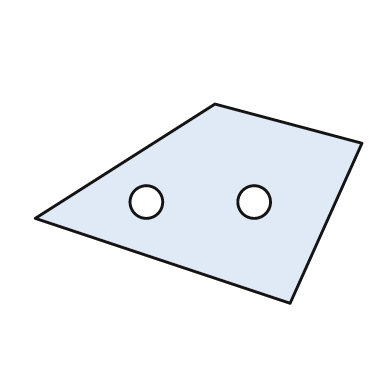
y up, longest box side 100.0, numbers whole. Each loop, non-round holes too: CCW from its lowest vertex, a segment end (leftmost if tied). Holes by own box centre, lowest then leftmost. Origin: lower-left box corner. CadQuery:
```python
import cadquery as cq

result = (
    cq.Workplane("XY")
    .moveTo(78.0, 0.0)
    .lineTo(100.0, 49.0)
    .lineTo(55.0, 61.0)
    .lineTo(0.0, 26.0)
    .close()
    .moveTo(34.0, 31.0)
    .circle(5.0)
    .moveTo(67.0, 31.0)
    .circle(5.0)
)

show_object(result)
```